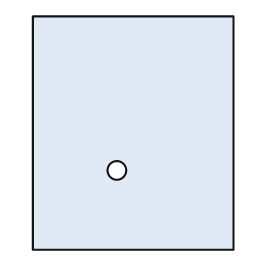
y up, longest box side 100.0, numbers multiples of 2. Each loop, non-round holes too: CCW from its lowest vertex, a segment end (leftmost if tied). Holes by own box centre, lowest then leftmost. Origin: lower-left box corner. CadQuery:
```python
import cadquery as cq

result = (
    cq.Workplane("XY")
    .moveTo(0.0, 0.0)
    .lineTo(86.0, 0.0)
    .lineTo(86.0, 100.0)
    .lineTo(0.0, 100.0)
    .close()
    .moveTo(36.0, 34.0)
    .circle(4.0)
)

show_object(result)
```